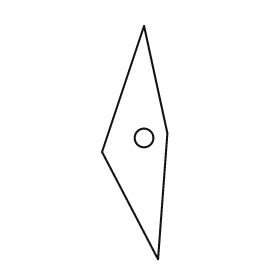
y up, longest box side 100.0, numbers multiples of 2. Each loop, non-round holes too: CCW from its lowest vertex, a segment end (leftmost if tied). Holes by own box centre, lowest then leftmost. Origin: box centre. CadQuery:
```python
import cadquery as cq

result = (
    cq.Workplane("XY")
    .moveTo(10.0, -50.0)
    .lineTo(14.0, 4.0)
    .lineTo(4.0, 50.0)
    .lineTo(-14.0, -4.0)
    .close()
    .moveTo(4.0, 2.0)
    .circle(4.0)
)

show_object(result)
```